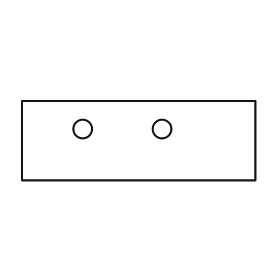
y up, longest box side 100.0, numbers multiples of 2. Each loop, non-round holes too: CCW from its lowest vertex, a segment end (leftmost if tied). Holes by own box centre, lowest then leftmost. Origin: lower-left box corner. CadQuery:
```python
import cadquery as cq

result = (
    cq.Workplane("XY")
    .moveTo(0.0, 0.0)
    .lineTo(100.0, 0.0)
    .lineTo(100.0, 34.0)
    .lineTo(0.0, 34.0)
    .close()
    .moveTo(26.0, 22.0)
    .circle(4.0)
    .moveTo(60.0, 22.0)
    .circle(4.0)
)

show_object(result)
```